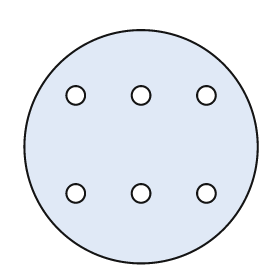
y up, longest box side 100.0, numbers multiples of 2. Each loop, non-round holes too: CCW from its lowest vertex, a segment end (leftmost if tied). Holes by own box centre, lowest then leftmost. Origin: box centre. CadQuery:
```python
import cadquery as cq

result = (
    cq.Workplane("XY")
    .moveTo(0.0, 0.0)
    .circle(50.0)
    .moveTo(-28.0, -20.0)
    .circle(4.0)
    .moveTo(0.0, -20.0)
    .circle(4.0)
    .moveTo(28.0, -20.0)
    .circle(4.0)
    .moveTo(-28.0, 22.0)
    .circle(4.0)
    .moveTo(0.0, 22.0)
    .circle(4.0)
    .moveTo(28.0, 22.0)
    .circle(4.0)
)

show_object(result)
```